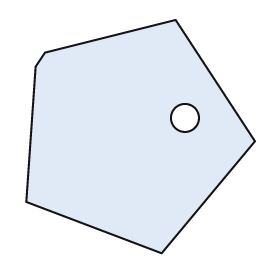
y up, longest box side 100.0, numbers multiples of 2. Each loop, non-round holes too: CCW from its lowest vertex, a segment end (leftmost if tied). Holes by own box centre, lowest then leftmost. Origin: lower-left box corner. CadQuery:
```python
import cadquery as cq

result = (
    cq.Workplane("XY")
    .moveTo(58.0, 0.0)
    .lineTo(98.0, 48.0)
    .lineTo(64.0, 100.0)
    .lineTo(8.0, 86.0)
    .lineTo(4.0, 80.0)
    .lineTo(0.0, 22.0)
    .close()
    .moveTo(68.0, 58.0)
    .circle(6.0)
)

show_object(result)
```